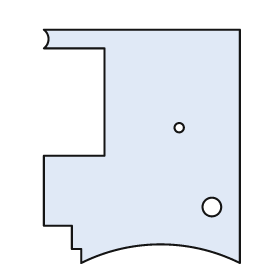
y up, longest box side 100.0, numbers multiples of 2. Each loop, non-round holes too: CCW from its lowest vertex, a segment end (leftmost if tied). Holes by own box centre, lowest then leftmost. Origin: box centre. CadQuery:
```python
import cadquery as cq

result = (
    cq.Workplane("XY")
    .moveTo(-26.0, -50.0)
    .threePointArc((8.0, -42.0), (42.0, -50.0))
    .lineTo(42.0, 50.0)
    .lineTo(-42.0, 50.0)
    .threePointArc((-40.0, 46.0), (-42.0, 42.0))
    .lineTo(-16.0, 42.0)
    .lineTo(-16.0, -4.0)
    .lineTo(-42.0, -4.0)
    .lineTo(-42.0, -34.0)
    .lineTo(-30.0, -34.0)
    .lineTo(-30.0, -44.0)
    .lineTo(-26.0, -44.0)
    .close()
    .moveTo(30.0, -26.0)
    .circle(4.0)
    .moveTo(16.0, 8.0)
    .circle(2.0)
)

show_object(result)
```